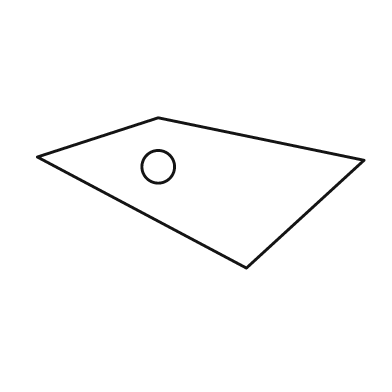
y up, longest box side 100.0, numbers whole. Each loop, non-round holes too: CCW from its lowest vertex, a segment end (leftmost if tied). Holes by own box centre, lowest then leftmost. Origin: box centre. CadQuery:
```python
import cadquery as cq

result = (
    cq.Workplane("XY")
    .moveTo(14.0, -23.0)
    .lineTo(50.0, 10.0)
    .lineTo(-13.0, 23.0)
    .lineTo(-50.0, 11.0)
    .close()
    .moveTo(-13.0, 8.0)
    .circle(5.0)
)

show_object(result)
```